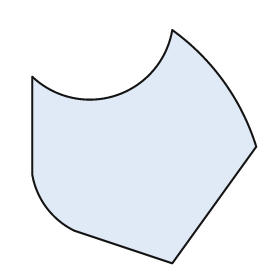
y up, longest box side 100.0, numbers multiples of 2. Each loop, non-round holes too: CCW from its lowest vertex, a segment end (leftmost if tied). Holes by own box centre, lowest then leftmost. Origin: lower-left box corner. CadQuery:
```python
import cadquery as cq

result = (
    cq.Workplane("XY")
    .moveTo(60.0, 0.0)
    .lineTo(96.0, 50.0)
    .threePointArc((82.0, 78.0), (60.0, 100.0))
    .threePointArc((36.0, 72.0), (0.0, 80.0))
    .lineTo(0.0, 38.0)
    .threePointArc((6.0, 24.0), (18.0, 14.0))
    .close()
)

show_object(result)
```